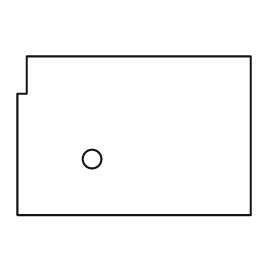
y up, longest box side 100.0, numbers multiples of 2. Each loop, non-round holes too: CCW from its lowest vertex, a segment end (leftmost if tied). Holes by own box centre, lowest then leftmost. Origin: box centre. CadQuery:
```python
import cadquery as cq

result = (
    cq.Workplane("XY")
    .moveTo(-50.0, -34.0)
    .lineTo(50.0, -34.0)
    .lineTo(50.0, 34.0)
    .lineTo(-46.0, 34.0)
    .lineTo(-46.0, 18.0)
    .lineTo(-50.0, 18.0)
    .close()
    .moveTo(-18.0, -10.0)
    .circle(4.0)
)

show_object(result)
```